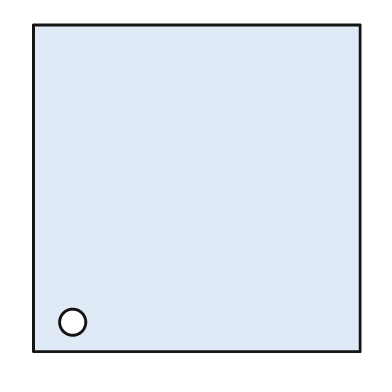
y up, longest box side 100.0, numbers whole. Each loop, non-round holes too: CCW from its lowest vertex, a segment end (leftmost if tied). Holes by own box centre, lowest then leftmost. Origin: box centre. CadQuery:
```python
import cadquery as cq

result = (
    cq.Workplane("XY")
    .moveTo(-50.0, -50.0)
    .lineTo(50.0, -50.0)
    .lineTo(50.0, 50.0)
    .lineTo(-50.0, 50.0)
    .close()
    .moveTo(-38.0, -41.0)
    .circle(4.0)
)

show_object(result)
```